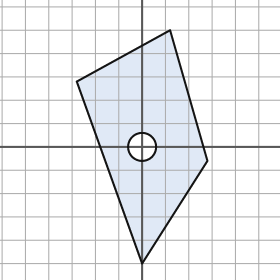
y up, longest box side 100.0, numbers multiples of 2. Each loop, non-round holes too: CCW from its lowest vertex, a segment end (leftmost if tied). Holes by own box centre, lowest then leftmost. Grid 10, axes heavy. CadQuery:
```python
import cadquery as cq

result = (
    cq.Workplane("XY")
    .moveTo(0.0, -50.0)
    .lineTo(28.0, -6.0)
    .lineTo(12.0, 50.0)
    .lineTo(-28.0, 28.0)
    .close()
    .moveTo(0.0, 0.0)
    .circle(6.0)
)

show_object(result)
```